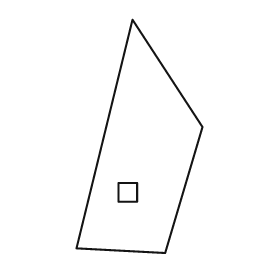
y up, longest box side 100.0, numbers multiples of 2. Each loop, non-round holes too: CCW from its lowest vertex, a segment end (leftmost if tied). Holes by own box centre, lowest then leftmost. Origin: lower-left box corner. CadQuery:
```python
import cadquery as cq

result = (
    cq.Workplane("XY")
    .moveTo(38.0, 0.0)
    .lineTo(54.0, 54.0)
    .lineTo(24.0, 100.0)
    .lineTo(0.0, 2.0)
    .close()
    .moveTo(18.0, 22.0)
    .lineTo(26.0, 22.0)
    .lineTo(26.0, 30.0)
    .lineTo(18.0, 30.0)
    .close()
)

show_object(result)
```